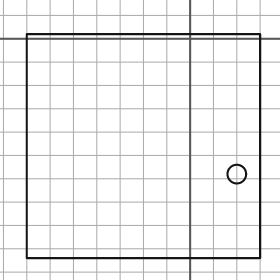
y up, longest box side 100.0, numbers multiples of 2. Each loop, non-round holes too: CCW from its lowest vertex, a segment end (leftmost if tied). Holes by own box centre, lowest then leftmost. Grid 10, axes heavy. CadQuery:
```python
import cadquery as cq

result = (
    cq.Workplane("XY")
    .moveTo(-70.0, -94.0)
    .lineTo(30.0, -94.0)
    .lineTo(30.0, 2.0)
    .lineTo(-70.0, 2.0)
    .close()
    .moveTo(20.0, -58.0)
    .circle(4.0)
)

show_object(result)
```